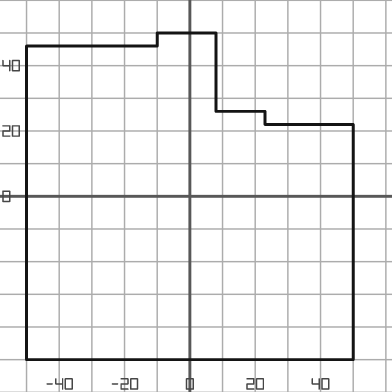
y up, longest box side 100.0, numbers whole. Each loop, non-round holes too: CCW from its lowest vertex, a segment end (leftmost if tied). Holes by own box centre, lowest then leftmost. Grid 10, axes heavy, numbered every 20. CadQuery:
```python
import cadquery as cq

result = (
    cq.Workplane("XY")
    .moveTo(-50.0, -50.0)
    .lineTo(50.0, -50.0)
    .lineTo(50.0, 22.0)
    .lineTo(23.0, 22.0)
    .lineTo(23.0, 26.0)
    .lineTo(8.0, 26.0)
    .lineTo(8.0, 50.0)
    .lineTo(-10.0, 50.0)
    .lineTo(-10.0, 46.0)
    .lineTo(-50.0, 46.0)
    .close()
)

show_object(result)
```